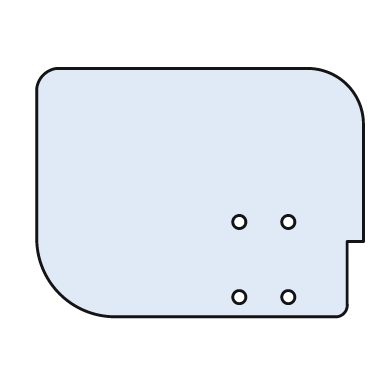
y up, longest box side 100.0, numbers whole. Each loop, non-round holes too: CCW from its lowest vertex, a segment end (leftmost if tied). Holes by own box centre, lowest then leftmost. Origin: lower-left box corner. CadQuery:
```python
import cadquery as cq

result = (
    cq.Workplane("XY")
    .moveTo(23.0, 0.0)
    .lineTo(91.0, 0.0)
    .threePointArc((94.0, 1.0), (95.0, 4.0))
    .lineTo(95.0, 23.0)
    .lineTo(100.0, 23.0)
    .lineTo(100.0, 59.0)
    .threePointArc((95.0, 71.0), (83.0, 76.0))
    .lineTo(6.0, 76.0)
    .threePointArc((2.0, 74.0), (0.0, 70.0))
    .lineTo(0.0, 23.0)
    .threePointArc((7.0, 7.0), (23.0, 0.0))
    .close()
    .moveTo(62.0, 6.0)
    .circle(2.0)
    .moveTo(77.0, 6.0)
    .circle(2.0)
    .moveTo(62.0, 29.0)
    .circle(2.0)
    .moveTo(77.0, 29.0)
    .circle(2.0)
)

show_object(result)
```